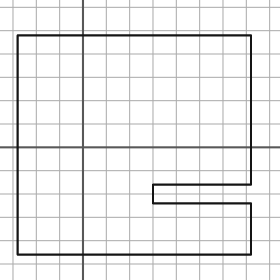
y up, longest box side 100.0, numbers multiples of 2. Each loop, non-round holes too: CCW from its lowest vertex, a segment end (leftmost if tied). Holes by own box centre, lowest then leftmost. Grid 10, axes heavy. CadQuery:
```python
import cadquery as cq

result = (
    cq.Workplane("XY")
    .moveTo(-28.0, -46.0)
    .lineTo(72.0, -46.0)
    .lineTo(72.0, -24.0)
    .lineTo(30.0, -24.0)
    .lineTo(30.0, -16.0)
    .lineTo(72.0, -16.0)
    .lineTo(72.0, 48.0)
    .lineTo(-28.0, 48.0)
    .close()
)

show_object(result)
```